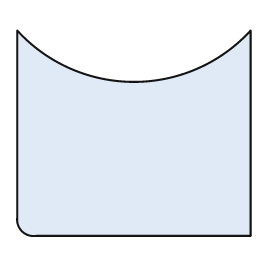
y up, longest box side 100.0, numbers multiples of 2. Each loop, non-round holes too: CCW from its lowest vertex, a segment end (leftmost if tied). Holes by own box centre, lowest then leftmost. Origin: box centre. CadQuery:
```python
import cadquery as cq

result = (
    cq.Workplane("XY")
    .moveTo(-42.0, -44.0)
    .lineTo(50.0, -44.0)
    .lineTo(50.0, 44.0)
    .threePointArc((0.0, 22.0), (-50.0, 44.0))
    .lineTo(-50.0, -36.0)
    .threePointArc((-48.0, -42.0), (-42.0, -44.0))
    .close()
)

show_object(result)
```